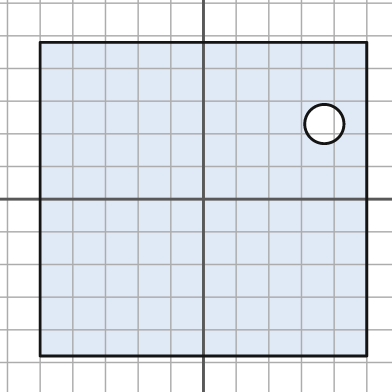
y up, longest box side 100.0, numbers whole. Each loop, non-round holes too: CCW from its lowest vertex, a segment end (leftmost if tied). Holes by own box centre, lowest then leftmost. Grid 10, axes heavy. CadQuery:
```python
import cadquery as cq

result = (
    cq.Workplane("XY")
    .moveTo(-50.0, -48.0)
    .lineTo(50.0, -48.0)
    .lineTo(50.0, 48.0)
    .lineTo(-50.0, 48.0)
    .close()
    .moveTo(37.0, 23.0)
    .circle(6.0)
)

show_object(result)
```